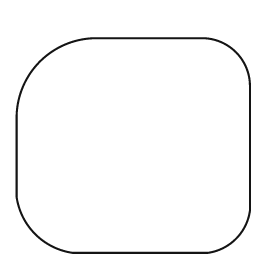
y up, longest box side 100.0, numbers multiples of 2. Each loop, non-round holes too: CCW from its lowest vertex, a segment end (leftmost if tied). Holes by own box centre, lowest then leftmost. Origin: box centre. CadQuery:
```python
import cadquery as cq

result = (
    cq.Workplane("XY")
    .moveTo(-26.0, -46.0)
    .lineTo(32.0, -46.0)
    .threePointArc((44.0, -40.0), (50.0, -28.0))
    .lineTo(50.0, 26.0)
    .threePointArc((44.0, 40.0), (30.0, 46.0))
    .lineTo(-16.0, 46.0)
    .threePointArc((-40.0, 36.0), (-50.0, 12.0))
    .lineTo(-50.0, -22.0)
    .threePointArc((-42.0, -38.0), (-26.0, -46.0))
    .close()
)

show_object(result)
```